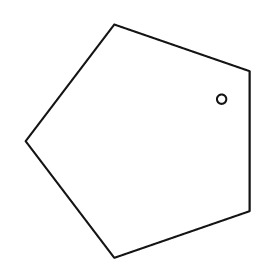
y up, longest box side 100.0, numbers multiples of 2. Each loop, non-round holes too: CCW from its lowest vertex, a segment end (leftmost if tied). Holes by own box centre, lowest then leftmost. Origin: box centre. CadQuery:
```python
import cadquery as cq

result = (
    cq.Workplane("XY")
    .moveTo(-10.0, -50.0)
    .lineTo(48.0, -30.0)
    .lineTo(48.0, 30.0)
    .lineTo(-10.0, 50.0)
    .lineTo(-48.0, 0.0)
    .close()
    .moveTo(36.0, 18.0)
    .circle(2.0)
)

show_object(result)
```